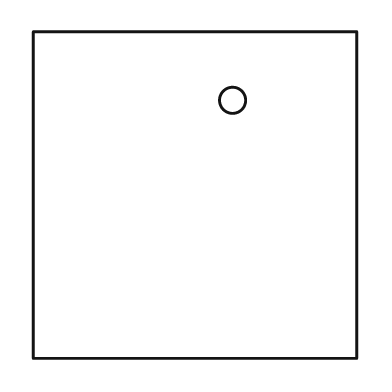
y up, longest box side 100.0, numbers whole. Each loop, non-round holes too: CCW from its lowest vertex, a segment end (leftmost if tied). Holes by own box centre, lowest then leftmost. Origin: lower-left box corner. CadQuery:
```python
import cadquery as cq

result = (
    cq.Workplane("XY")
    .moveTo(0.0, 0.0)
    .lineTo(99.0, 0.0)
    .lineTo(99.0, 100.0)
    .lineTo(0.0, 100.0)
    .close()
    .moveTo(61.0, 79.0)
    .circle(4.0)
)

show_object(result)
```